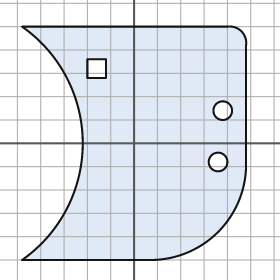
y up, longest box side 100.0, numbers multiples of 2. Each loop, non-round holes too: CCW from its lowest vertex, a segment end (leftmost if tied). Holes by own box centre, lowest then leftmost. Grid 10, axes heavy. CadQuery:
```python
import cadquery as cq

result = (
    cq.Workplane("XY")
    .moveTo(-48.0, -50.0)
    .lineTo(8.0, -50.0)
    .threePointArc((36.0, -38.0), (48.0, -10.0))
    .lineTo(48.0, 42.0)
    .threePointArc((46.0, 48.0), (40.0, 50.0))
    .lineTo(-48.0, 50.0)
    .threePointArc((-22.0, 0.0), (-48.0, -50.0))
    .close()
    .moveTo(36.0, -8.0)
    .circle(4.0)
    .moveTo(38.0, 14.0)
    .circle(4.0)
    .moveTo(-20.0, 28.0)
    .lineTo(-12.0, 28.0)
    .lineTo(-12.0, 36.0)
    .lineTo(-20.0, 36.0)
    .close()
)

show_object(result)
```